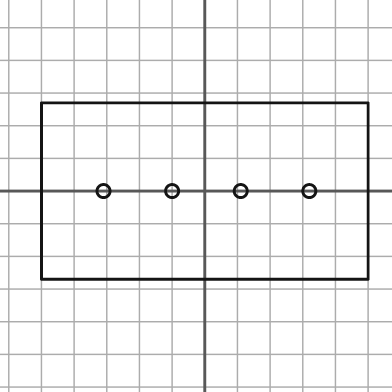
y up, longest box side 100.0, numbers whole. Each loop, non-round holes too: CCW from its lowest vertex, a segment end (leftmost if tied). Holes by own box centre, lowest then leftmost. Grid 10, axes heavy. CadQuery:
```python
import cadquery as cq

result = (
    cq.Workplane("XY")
    .moveTo(-50.0, -27.0)
    .lineTo(50.0, -27.0)
    .lineTo(50.0, 27.0)
    .lineTo(-50.0, 27.0)
    .close()
    .moveTo(-31.0, 0.0)
    .circle(2.0)
    .moveTo(-10.0, 0.0)
    .circle(2.0)
    .moveTo(11.0, 0.0)
    .circle(2.0)
    .moveTo(32.0, 0.0)
    .circle(2.0)
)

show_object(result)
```